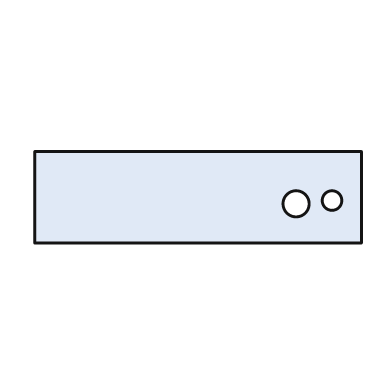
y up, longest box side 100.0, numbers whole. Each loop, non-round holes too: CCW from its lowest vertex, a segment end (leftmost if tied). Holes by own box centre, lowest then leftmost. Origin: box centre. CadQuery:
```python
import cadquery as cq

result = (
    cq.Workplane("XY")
    .moveTo(-50.0, -14.0)
    .lineTo(50.0, -14.0)
    .lineTo(50.0, 14.0)
    .lineTo(-50.0, 14.0)
    .close()
    .moveTo(30.0, -2.0)
    .circle(4.0)
    .moveTo(41.0, -1.0)
    .circle(3.0)
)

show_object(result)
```